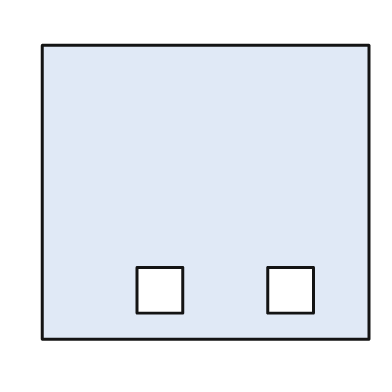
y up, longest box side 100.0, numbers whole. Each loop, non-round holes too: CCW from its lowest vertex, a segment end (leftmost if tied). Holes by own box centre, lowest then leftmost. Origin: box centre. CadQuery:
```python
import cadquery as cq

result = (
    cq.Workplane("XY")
    .moveTo(-50.0, -45.0)
    .lineTo(50.0, -45.0)
    .lineTo(50.0, 45.0)
    .lineTo(-50.0, 45.0)
    .close()
    .moveTo(-21.0, -37.0)
    .lineTo(-7.0, -37.0)
    .lineTo(-7.0, -23.0)
    .lineTo(-21.0, -23.0)
    .close()
    .moveTo(19.0, -37.0)
    .lineTo(33.0, -37.0)
    .lineTo(33.0, -23.0)
    .lineTo(19.0, -23.0)
    .close()
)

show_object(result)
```